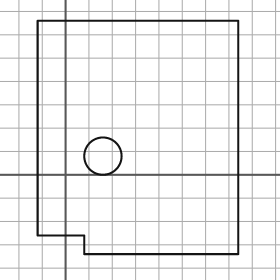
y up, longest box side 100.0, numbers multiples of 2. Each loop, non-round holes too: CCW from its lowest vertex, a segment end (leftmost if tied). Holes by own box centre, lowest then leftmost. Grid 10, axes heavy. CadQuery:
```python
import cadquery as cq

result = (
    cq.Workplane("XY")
    .moveTo(8.0, -34.0)
    .lineTo(74.0, -34.0)
    .lineTo(74.0, 66.0)
    .lineTo(-12.0, 66.0)
    .lineTo(-12.0, -26.0)
    .lineTo(8.0, -26.0)
    .close()
    .moveTo(16.0, 8.0)
    .circle(8.0)
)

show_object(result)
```